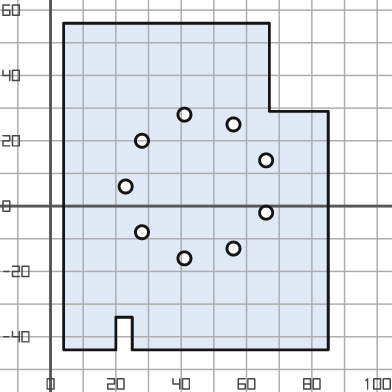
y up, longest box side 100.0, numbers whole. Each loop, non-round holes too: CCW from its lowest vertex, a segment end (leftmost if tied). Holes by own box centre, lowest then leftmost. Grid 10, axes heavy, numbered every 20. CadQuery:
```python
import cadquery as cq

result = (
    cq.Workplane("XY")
    .moveTo(4.0, -44.0)
    .lineTo(20.0, -44.0)
    .lineTo(20.0, -34.0)
    .lineTo(25.0, -34.0)
    .lineTo(25.0, -44.0)
    .lineTo(85.0, -44.0)
    .lineTo(85.0, 29.0)
    .lineTo(67.0, 29.0)
    .lineTo(67.0, 56.0)
    .lineTo(4.0, 56.0)
    .close()
    .moveTo(41.0, -16.0)
    .circle(2.0)
    .moveTo(56.0, -13.0)
    .circle(2.0)
    .moveTo(28.0, -8.0)
    .circle(2.0)
    .moveTo(66.0, -2.0)
    .circle(2.0)
    .moveTo(23.0, 6.0)
    .circle(2.0)
    .moveTo(66.0, 14.0)
    .circle(2.0)
    .moveTo(28.0, 20.0)
    .circle(2.0)
    .moveTo(56.0, 25.0)
    .circle(2.0)
    .moveTo(41.0, 28.0)
    .circle(2.0)
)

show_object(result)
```